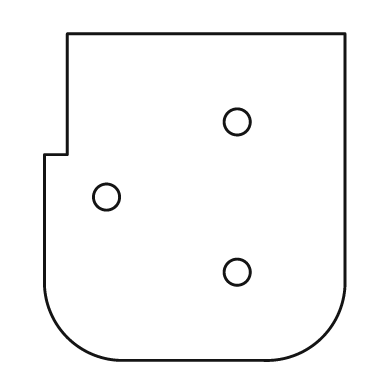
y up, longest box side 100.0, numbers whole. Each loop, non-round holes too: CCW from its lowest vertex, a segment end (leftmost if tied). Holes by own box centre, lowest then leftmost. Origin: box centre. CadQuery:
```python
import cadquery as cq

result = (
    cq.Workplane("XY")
    .moveTo(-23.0, -50.0)
    .lineTo(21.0, -50.0)
    .threePointArc((39.0, -43.0), (46.0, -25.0))
    .lineTo(46.0, 50.0)
    .lineTo(-39.0, 50.0)
    .lineTo(-39.0, 13.0)
    .lineTo(-46.0, 13.0)
    .lineTo(-46.0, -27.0)
    .threePointArc((-39.0, -43.0), (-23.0, -50.0))
    .close()
    .moveTo(13.0, -23.0)
    .circle(4.0)
    .moveTo(-27.0, 0.0)
    .circle(4.0)
    .moveTo(13.0, 23.0)
    .circle(4.0)
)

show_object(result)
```